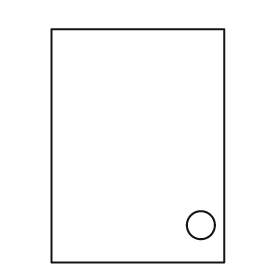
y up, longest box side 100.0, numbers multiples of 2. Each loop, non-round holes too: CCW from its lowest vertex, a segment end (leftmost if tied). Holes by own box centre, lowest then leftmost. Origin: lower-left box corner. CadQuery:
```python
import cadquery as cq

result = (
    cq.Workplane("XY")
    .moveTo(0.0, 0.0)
    .lineTo(74.0, 0.0)
    .lineTo(74.0, 100.0)
    .lineTo(0.0, 100.0)
    .close()
    .moveTo(64.0, 16.0)
    .circle(6.0)
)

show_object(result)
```